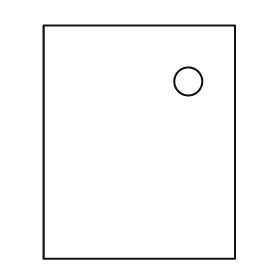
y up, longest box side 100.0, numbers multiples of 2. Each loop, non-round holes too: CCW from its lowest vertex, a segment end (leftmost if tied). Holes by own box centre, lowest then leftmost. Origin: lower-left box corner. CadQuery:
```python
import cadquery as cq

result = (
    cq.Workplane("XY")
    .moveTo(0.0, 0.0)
    .lineTo(82.0, 0.0)
    .lineTo(82.0, 100.0)
    .lineTo(0.0, 100.0)
    .close()
    .moveTo(62.0, 76.0)
    .circle(6.0)
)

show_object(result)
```